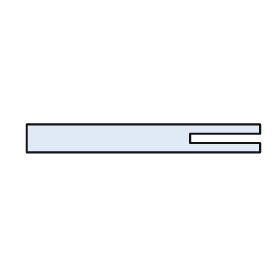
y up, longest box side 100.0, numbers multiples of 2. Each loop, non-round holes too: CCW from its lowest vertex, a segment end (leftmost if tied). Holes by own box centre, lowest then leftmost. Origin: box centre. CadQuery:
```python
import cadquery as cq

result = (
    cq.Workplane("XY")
    .moveTo(-50.0, -6.0)
    .lineTo(50.0, -6.0)
    .lineTo(50.0, -2.0)
    .lineTo(20.0, -2.0)
    .lineTo(20.0, 2.0)
    .lineTo(50.0, 2.0)
    .lineTo(50.0, 6.0)
    .lineTo(-50.0, 6.0)
    .close()
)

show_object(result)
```